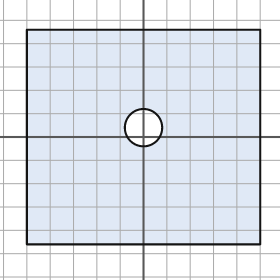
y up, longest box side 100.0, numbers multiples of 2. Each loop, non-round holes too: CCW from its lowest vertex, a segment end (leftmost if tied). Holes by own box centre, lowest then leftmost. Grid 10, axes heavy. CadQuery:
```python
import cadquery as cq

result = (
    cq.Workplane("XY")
    .moveTo(-50.0, -46.0)
    .lineTo(50.0, -46.0)
    .lineTo(50.0, 46.0)
    .lineTo(-50.0, 46.0)
    .close()
    .moveTo(0.0, 4.0)
    .circle(8.0)
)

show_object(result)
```